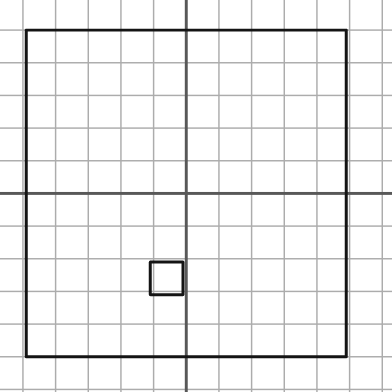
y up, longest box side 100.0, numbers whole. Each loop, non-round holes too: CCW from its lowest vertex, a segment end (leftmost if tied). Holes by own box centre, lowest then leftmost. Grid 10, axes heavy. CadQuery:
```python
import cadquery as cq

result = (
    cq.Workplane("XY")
    .moveTo(-49.0, -50.0)
    .lineTo(49.0, -50.0)
    .lineTo(49.0, 50.0)
    .lineTo(-49.0, 50.0)
    .close()
    .moveTo(-11.0, -31.0)
    .lineTo(-1.0, -31.0)
    .lineTo(-1.0, -21.0)
    .lineTo(-11.0, -21.0)
    .close()
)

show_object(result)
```